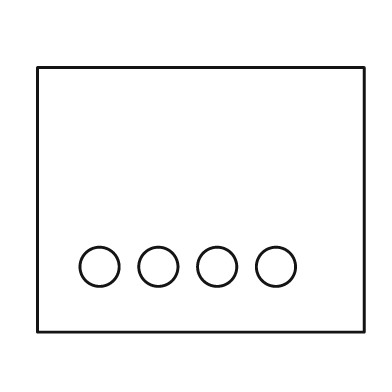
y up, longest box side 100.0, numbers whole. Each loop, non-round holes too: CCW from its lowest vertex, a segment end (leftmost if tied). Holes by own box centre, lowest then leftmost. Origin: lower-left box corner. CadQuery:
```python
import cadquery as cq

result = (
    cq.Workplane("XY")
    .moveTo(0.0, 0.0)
    .lineTo(100.0, 0.0)
    .lineTo(100.0, 81.0)
    .lineTo(0.0, 81.0)
    .close()
    .moveTo(19.0, 20.0)
    .circle(6.0)
    .moveTo(37.0, 20.0)
    .circle(6.0)
    .moveTo(55.0, 20.0)
    .circle(6.0)
    .moveTo(73.0, 20.0)
    .circle(6.0)
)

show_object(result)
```